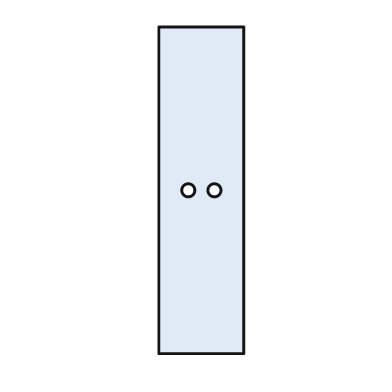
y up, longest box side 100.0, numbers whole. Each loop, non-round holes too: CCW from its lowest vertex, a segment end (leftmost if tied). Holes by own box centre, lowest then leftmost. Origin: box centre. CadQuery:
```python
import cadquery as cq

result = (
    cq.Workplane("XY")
    .moveTo(-13.0, -50.0)
    .lineTo(13.0, -50.0)
    .lineTo(13.0, 50.0)
    .lineTo(-13.0, 50.0)
    .close()
    .moveTo(-4.0, 0.0)
    .circle(2.0)
    .moveTo(4.0, 0.0)
    .circle(2.0)
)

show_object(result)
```